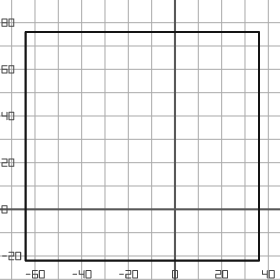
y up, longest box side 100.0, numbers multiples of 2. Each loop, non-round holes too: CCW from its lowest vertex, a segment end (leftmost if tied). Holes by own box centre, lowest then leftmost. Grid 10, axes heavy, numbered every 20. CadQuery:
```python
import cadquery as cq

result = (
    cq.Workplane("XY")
    .moveTo(-64.0, -22.0)
    .lineTo(36.0, -22.0)
    .lineTo(36.0, 76.0)
    .lineTo(-64.0, 76.0)
    .close()
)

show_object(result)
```